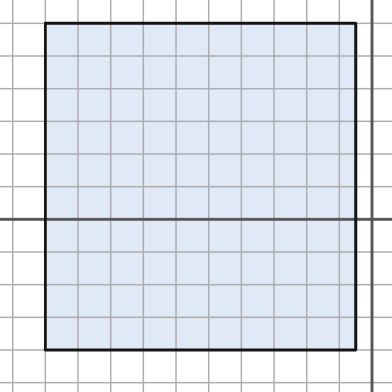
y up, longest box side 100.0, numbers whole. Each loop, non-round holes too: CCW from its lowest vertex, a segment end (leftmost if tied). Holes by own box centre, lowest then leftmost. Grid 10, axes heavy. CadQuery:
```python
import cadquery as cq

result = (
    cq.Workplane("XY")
    .moveTo(-100.0, -40.0)
    .lineTo(-5.0, -40.0)
    .lineTo(-5.0, 60.0)
    .lineTo(-100.0, 60.0)
    .close()
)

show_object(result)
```